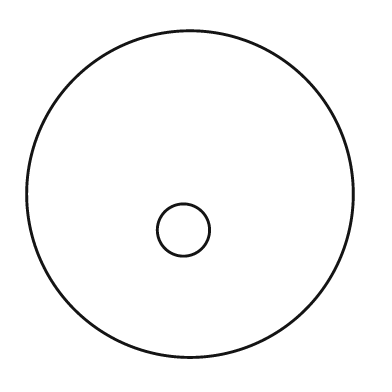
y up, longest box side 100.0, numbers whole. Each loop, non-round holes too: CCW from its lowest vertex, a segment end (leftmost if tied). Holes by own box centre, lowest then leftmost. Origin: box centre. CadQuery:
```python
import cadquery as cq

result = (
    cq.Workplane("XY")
    .moveTo(0.0, 0.0)
    .circle(50.0)
    .moveTo(-2.0, -11.0)
    .circle(8.0)
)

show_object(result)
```